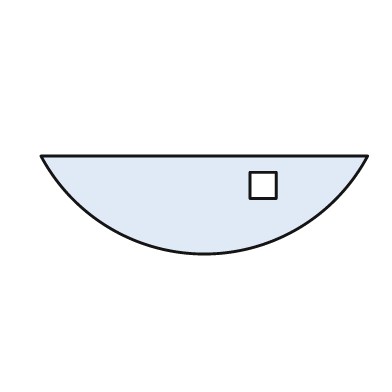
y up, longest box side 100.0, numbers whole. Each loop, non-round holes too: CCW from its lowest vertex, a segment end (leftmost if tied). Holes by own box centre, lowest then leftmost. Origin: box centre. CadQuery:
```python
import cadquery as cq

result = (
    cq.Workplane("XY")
    .moveTo(-50.0, 15.0)
    .threePointArc((0.0, -15.0), (50.0, 15.0))
    .close()
    .moveTo(14.0, 2.0)
    .lineTo(22.0, 2.0)
    .lineTo(22.0, 10.0)
    .lineTo(14.0, 10.0)
    .close()
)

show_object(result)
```